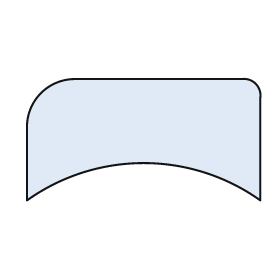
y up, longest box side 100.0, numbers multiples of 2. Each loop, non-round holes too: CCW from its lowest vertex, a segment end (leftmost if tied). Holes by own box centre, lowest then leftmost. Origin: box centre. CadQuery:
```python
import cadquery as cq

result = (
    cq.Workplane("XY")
    .moveTo(-50.0, -26.0)
    .threePointArc((0.0, -10.0), (50.0, -26.0))
    .lineTo(50.0, 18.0)
    .threePointArc((48.0, 24.0), (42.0, 26.0))
    .lineTo(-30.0, 26.0)
    .threePointArc((-44.0, 20.0), (-50.0, 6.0))
    .close()
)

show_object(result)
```